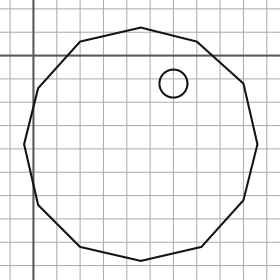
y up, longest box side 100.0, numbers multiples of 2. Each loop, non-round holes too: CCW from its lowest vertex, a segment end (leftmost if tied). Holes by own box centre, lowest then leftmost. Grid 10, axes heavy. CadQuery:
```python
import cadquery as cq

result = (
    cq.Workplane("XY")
    .moveTo(46.0, -88.0)
    .lineTo(72.0, -82.0)
    .lineTo(90.0, -62.0)
    .lineTo(96.0, -38.0)
    .lineTo(90.0, -12.0)
    .lineTo(70.0, 6.0)
    .lineTo(46.0, 12.0)
    .lineTo(20.0, 6.0)
    .lineTo(2.0, -14.0)
    .lineTo(-4.0, -38.0)
    .lineTo(2.0, -64.0)
    .lineTo(20.0, -82.0)
    .close()
    .moveTo(60.0, -12.0)
    .circle(6.0)
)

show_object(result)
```